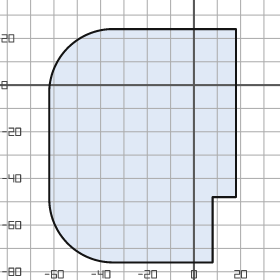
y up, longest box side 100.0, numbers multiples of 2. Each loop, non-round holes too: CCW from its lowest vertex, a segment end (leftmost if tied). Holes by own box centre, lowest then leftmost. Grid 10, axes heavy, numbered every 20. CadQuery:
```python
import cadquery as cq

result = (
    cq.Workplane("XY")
    .moveTo(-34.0, -76.0)
    .lineTo(8.0, -76.0)
    .lineTo(8.0, -48.0)
    .lineTo(18.0, -48.0)
    .lineTo(18.0, 24.0)
    .lineTo(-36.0, 24.0)
    .threePointArc((-54.0, 16.0), (-62.0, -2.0))
    .lineTo(-62.0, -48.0)
    .threePointArc((-54.0, -68.0), (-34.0, -76.0))
    .close()
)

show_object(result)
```